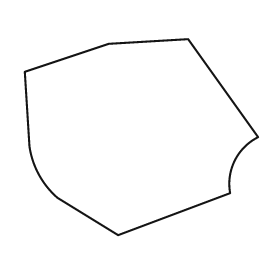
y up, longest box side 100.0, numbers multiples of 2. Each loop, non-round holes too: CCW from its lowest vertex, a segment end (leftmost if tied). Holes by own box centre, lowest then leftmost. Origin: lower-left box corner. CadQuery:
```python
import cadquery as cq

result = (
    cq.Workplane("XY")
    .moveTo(40.0, 0.0)
    .lineTo(88.0, 18.0)
    .threePointArc((90.0, 32.0), (100.0, 42.0))
    .lineTo(70.0, 84.0)
    .lineTo(36.0, 82.0)
    .lineTo(0.0, 70.0)
    .lineTo(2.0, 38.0)
    .threePointArc((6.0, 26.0), (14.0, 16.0))
    .close()
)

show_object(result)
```